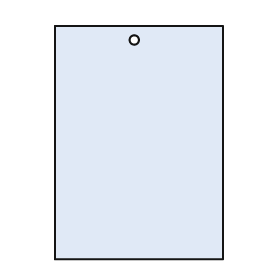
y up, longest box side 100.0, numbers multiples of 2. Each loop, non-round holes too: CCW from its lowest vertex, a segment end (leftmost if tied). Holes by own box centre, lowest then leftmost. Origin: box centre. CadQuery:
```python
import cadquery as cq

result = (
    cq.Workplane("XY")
    .moveTo(-36.0, -50.0)
    .lineTo(36.0, -50.0)
    .lineTo(36.0, 50.0)
    .lineTo(-36.0, 50.0)
    .close()
    .moveTo(-2.0, 44.0)
    .circle(2.0)
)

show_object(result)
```